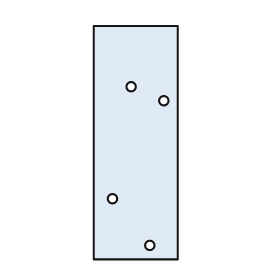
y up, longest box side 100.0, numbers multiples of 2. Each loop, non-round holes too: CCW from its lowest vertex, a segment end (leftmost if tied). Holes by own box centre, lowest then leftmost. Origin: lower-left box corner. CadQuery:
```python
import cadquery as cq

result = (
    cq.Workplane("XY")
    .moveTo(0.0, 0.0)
    .lineTo(36.0, 0.0)
    .lineTo(36.0, 100.0)
    .lineTo(0.0, 100.0)
    .close()
    .moveTo(24.0, 6.0)
    .circle(2.0)
    .moveTo(8.0, 26.0)
    .circle(2.0)
    .moveTo(30.0, 68.0)
    .circle(2.0)
    .moveTo(16.0, 74.0)
    .circle(2.0)
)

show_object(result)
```